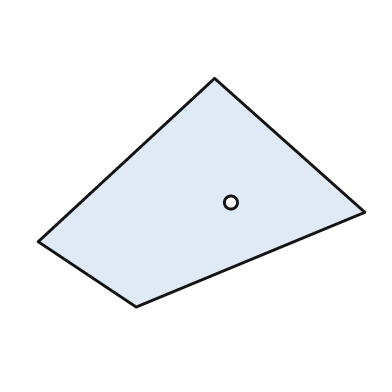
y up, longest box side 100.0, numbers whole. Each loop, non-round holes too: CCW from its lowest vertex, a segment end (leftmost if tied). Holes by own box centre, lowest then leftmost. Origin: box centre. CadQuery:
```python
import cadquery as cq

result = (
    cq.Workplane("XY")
    .moveTo(-20.0, -35.0)
    .lineTo(50.0, -6.0)
    .lineTo(4.0, 35.0)
    .lineTo(-50.0, -15.0)
    .close()
    .moveTo(9.0, -3.0)
    .circle(2.0)
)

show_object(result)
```